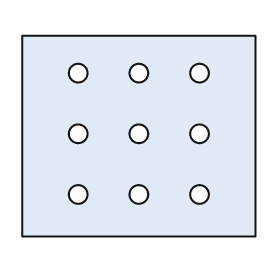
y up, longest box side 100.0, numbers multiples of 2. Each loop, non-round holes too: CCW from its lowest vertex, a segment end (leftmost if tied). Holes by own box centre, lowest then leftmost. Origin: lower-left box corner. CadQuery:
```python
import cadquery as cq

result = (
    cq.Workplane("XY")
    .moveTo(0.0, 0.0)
    .lineTo(100.0, 0.0)
    .lineTo(100.0, 86.0)
    .lineTo(0.0, 86.0)
    .close()
    .moveTo(24.0, 18.0)
    .circle(4.0)
    .moveTo(50.0, 18.0)
    .circle(4.0)
    .moveTo(76.0, 18.0)
    .circle(4.0)
    .moveTo(24.0, 44.0)
    .circle(4.0)
    .moveTo(50.0, 44.0)
    .circle(4.0)
    .moveTo(76.0, 44.0)
    .circle(4.0)
    .moveTo(24.0, 70.0)
    .circle(4.0)
    .moveTo(50.0, 70.0)
    .circle(4.0)
    .moveTo(76.0, 70.0)
    .circle(4.0)
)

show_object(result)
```